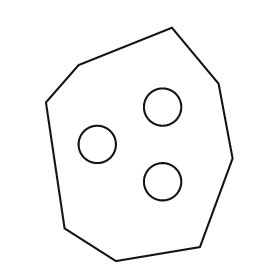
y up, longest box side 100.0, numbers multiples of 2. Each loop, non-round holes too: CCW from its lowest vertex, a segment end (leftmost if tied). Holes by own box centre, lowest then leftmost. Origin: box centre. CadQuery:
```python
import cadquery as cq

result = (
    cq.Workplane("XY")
    .moveTo(-10.0, -50.0)
    .lineTo(26.0, -44.0)
    .lineTo(40.0, -6.0)
    .lineTo(34.0, 26.0)
    .lineTo(14.0, 50.0)
    .lineTo(-26.0, 34.0)
    .lineTo(-40.0, 18.0)
    .lineTo(-32.0, -36.0)
    .close()
    .moveTo(10.0, -16.0)
    .circle(8.0)
    .moveTo(-18.0, 0.0)
    .circle(8.0)
    .moveTo(10.0, 16.0)
    .circle(8.0)
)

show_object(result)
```